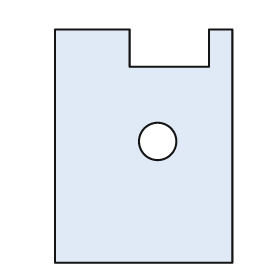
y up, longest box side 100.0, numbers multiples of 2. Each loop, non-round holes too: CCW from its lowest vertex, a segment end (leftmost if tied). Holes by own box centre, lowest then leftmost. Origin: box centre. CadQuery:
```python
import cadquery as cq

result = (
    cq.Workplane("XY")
    .moveTo(-38.0, -50.0)
    .lineTo(38.0, -50.0)
    .lineTo(38.0, 50.0)
    .lineTo(28.0, 50.0)
    .lineTo(28.0, 34.0)
    .lineTo(-6.0, 34.0)
    .lineTo(-6.0, 50.0)
    .lineTo(-38.0, 50.0)
    .close()
    .moveTo(6.0, 2.0)
    .circle(8.0)
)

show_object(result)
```